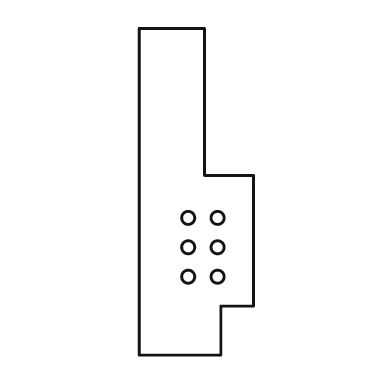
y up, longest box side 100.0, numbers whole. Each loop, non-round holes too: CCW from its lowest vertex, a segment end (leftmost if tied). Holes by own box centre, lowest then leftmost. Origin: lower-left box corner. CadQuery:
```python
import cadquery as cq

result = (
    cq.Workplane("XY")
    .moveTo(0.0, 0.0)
    .lineTo(25.0, 0.0)
    .lineTo(25.0, 15.0)
    .lineTo(35.0, 15.0)
    .lineTo(35.0, 55.0)
    .lineTo(20.0, 55.0)
    .lineTo(20.0, 100.0)
    .lineTo(0.0, 100.0)
    .close()
    .moveTo(15.0, 24.0)
    .circle(2.0)
    .moveTo(24.0, 24.0)
    .circle(2.0)
    .moveTo(15.0, 33.0)
    .circle(2.0)
    .moveTo(24.0, 33.0)
    .circle(2.0)
    .moveTo(15.0, 42.0)
    .circle(2.0)
    .moveTo(24.0, 42.0)
    .circle(2.0)
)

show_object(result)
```